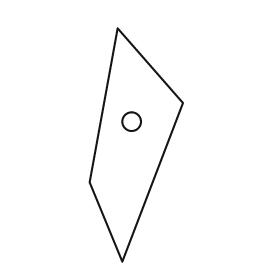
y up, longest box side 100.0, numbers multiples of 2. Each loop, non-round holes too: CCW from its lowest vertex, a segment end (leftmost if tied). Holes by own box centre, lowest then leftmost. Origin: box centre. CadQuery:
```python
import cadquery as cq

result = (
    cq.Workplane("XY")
    .moveTo(-6.0, -50.0)
    .lineTo(20.0, 18.0)
    .lineTo(-8.0, 50.0)
    .lineTo(-20.0, -16.0)
    .close()
    .moveTo(-2.0, 10.0)
    .circle(4.0)
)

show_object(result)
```